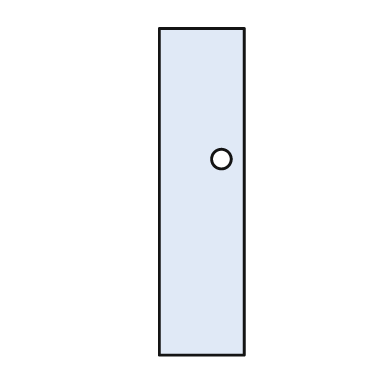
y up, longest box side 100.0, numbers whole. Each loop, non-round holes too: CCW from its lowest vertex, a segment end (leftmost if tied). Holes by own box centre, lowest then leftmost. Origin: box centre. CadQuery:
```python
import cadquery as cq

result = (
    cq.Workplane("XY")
    .moveTo(-13.0, -50.0)
    .lineTo(13.0, -50.0)
    .lineTo(13.0, 50.0)
    .lineTo(-13.0, 50.0)
    .close()
    .moveTo(6.0, 10.0)
    .circle(3.0)
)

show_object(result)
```